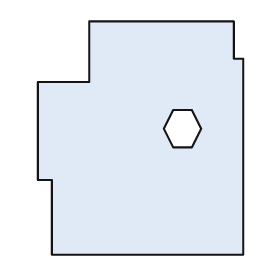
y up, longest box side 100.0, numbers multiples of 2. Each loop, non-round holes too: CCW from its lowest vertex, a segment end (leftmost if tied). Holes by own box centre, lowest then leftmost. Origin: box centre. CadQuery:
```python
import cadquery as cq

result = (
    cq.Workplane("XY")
    .moveTo(-38.0, -50.0)
    .lineTo(44.0, -50.0)
    .lineTo(44.0, 34.0)
    .lineTo(40.0, 34.0)
    .lineTo(40.0, 50.0)
    .lineTo(-22.0, 50.0)
    .lineTo(-22.0, 24.0)
    .lineTo(-44.0, 24.0)
    .lineTo(-44.0, -18.0)
    .lineTo(-38.0, -18.0)
    .close()
    .moveTo(14.0, -4.0)
    .lineTo(22.0, -4.0)
    .lineTo(26.0, 4.0)
    .lineTo(22.0, 12.0)
    .lineTo(14.0, 12.0)
    .lineTo(10.0, 4.0)
    .close()
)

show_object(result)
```